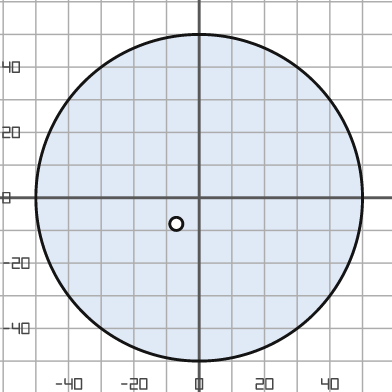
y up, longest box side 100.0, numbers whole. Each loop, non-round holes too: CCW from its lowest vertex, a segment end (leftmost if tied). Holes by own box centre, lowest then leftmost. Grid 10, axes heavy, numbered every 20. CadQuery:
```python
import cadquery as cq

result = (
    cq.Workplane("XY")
    .moveTo(0.0, 0.0)
    .circle(50.0)
    .moveTo(-7.0, -8.0)
    .circle(2.0)
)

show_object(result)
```